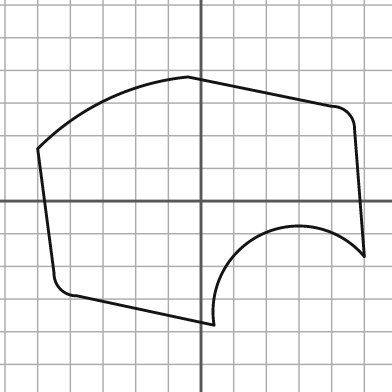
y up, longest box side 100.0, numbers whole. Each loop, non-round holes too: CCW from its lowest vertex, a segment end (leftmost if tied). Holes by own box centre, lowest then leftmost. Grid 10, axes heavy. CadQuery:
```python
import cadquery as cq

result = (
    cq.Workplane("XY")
    .moveTo(4.0, -38.0)
    .threePointArc((19.0, -10.0), (50.0, -17.0))
    .lineTo(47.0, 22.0)
    .threePointArc((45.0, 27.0), (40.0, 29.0))
    .lineTo(-4.0, 38.0)
    .threePointArc((-29.0, 31.0), (-50.0, 16.0))
    .lineTo(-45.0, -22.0)
    .threePointArc((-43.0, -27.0), (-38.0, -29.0))
    .close()
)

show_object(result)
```